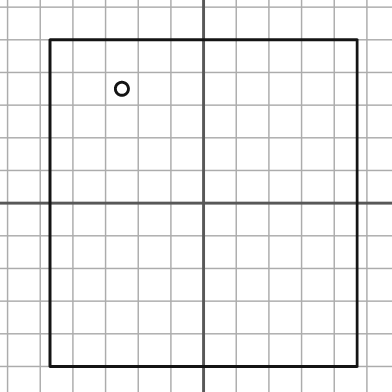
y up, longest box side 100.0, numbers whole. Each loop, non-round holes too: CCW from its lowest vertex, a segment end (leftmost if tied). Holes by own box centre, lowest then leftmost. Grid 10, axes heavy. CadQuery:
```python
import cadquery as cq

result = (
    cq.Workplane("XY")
    .moveTo(-47.0, -50.0)
    .lineTo(47.0, -50.0)
    .lineTo(47.0, 50.0)
    .lineTo(-47.0, 50.0)
    .close()
    .moveTo(-25.0, 35.0)
    .circle(2.0)
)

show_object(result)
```